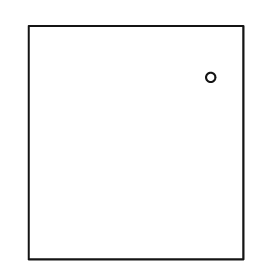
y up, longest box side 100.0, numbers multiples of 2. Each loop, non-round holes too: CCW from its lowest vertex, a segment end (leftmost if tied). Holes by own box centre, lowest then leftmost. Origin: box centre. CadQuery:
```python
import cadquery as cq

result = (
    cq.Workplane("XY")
    .moveTo(-46.0, -50.0)
    .lineTo(46.0, -50.0)
    .lineTo(46.0, 50.0)
    .lineTo(-46.0, 50.0)
    .close()
    .moveTo(32.0, 28.0)
    .circle(2.0)
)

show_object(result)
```